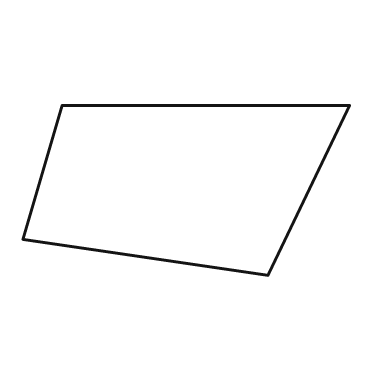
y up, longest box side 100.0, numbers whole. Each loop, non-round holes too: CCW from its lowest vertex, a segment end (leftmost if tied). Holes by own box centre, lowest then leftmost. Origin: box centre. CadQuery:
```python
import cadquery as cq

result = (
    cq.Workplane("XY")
    .moveTo(25.0, -26.0)
    .lineTo(50.0, 26.0)
    .lineTo(-38.0, 26.0)
    .lineTo(-50.0, -15.0)
    .close()
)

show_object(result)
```